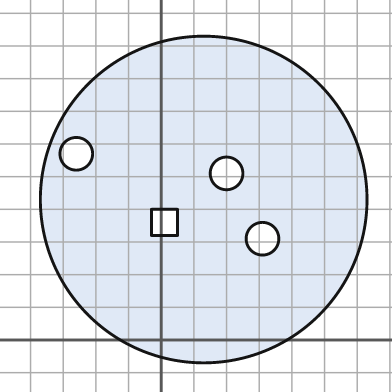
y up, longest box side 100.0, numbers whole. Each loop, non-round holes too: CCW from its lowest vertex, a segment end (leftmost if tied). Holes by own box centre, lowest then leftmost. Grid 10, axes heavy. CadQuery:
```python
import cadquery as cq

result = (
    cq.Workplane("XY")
    .moveTo(13.0, 43.0)
    .circle(50.0)
    .moveTo(31.0, 31.0)
    .circle(5.0)
    .moveTo(-3.0, 32.0)
    .lineTo(5.0, 32.0)
    .lineTo(5.0, 40.0)
    .lineTo(-3.0, 40.0)
    .close()
    .moveTo(20.0, 51.0)
    .circle(5.0)
    .moveTo(-26.0, 57.0)
    .circle(5.0)
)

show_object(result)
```